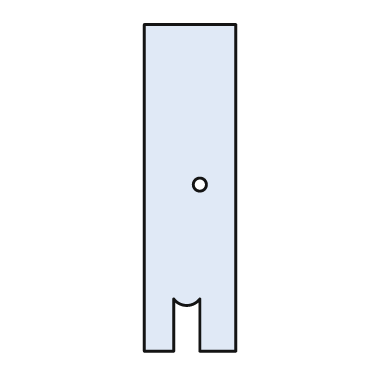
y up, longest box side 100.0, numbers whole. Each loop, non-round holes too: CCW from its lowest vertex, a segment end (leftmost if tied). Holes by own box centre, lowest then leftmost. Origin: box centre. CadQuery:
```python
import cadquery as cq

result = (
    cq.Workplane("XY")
    .moveTo(-14.0, -50.0)
    .lineTo(-5.0, -50.0)
    .lineTo(-5.0, -34.0)
    .threePointArc((-1.0, -36.0), (3.0, -34.0))
    .lineTo(3.0, -50.0)
    .lineTo(14.0, -50.0)
    .lineTo(14.0, 50.0)
    .lineTo(-14.0, 50.0)
    .close()
    .moveTo(3.0, 1.0)
    .circle(2.0)
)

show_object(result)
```